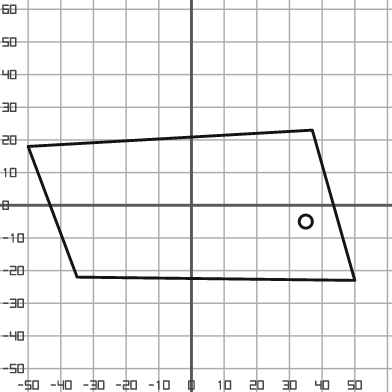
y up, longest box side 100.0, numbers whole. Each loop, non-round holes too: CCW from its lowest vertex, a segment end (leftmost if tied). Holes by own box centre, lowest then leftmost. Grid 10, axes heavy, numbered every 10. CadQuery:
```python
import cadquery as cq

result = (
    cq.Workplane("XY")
    .moveTo(50.0, -23.0)
    .lineTo(37.0, 23.0)
    .lineTo(-50.0, 18.0)
    .lineTo(-35.0, -22.0)
    .close()
    .moveTo(35.0, -5.0)
    .circle(2.0)
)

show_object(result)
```